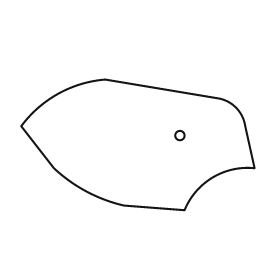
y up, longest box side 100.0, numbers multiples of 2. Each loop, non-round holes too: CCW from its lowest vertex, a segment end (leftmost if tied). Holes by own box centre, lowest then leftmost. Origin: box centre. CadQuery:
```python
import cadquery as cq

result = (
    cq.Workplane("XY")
    .moveTo(20.0, -28.0)
    .threePointArc((32.0, -14.0), (50.0, -10.0))
    .lineTo(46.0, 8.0)
    .threePointArc((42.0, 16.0), (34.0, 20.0))
    .lineTo(-14.0, 28.0)
    .threePointArc((-34.0, 22.0), (-50.0, 8.0))
    .lineTo(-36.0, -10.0)
    .threePointArc((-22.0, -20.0), (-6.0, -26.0))
    .close()
    .moveTo(18.0, 4.0)
    .circle(2.0)
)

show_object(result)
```